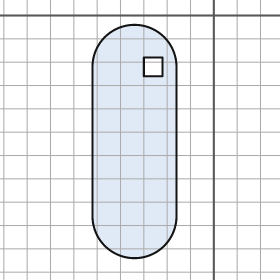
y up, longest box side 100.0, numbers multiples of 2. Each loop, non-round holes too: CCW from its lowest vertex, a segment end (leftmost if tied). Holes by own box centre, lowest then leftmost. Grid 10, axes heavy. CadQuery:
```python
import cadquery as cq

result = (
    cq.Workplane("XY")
    .moveTo(-52.0, -86.0)
    .threePointArc((-34.0, -104.0), (-16.0, -86.0))
    .lineTo(-16.0, -22.0)
    .threePointArc((-34.0, -4.0), (-52.0, -22.0))
    .close()
    .moveTo(-30.0, -26.0)
    .lineTo(-22.0, -26.0)
    .lineTo(-22.0, -18.0)
    .lineTo(-30.0, -18.0)
    .close()
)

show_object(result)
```